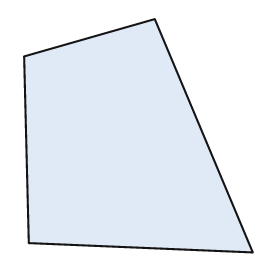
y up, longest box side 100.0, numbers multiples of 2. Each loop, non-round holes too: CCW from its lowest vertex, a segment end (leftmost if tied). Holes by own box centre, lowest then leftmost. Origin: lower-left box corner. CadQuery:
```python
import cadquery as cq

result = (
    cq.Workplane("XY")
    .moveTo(98.0, 0.0)
    .lineTo(56.0, 100.0)
    .lineTo(0.0, 84.0)
    .lineTo(2.0, 4.0)
    .close()
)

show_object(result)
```